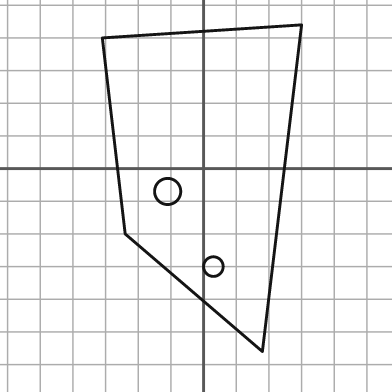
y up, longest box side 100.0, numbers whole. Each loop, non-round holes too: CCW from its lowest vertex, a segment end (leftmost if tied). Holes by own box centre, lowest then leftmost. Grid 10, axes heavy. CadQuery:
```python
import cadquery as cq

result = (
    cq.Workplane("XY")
    .moveTo(18.0, -56.0)
    .lineTo(30.0, 44.0)
    .lineTo(-31.0, 40.0)
    .lineTo(-24.0, -20.0)
    .close()
    .moveTo(3.0, -30.0)
    .circle(3.0)
    .moveTo(-11.0, -7.0)
    .circle(4.0)
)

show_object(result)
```